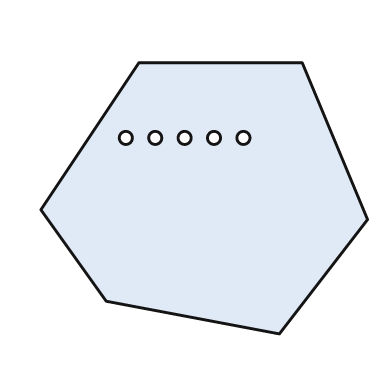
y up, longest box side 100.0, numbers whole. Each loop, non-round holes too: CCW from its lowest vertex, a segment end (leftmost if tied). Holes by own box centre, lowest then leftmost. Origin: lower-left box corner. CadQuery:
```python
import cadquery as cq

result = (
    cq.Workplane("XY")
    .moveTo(73.0, 0.0)
    .lineTo(100.0, 35.0)
    .lineTo(80.0, 83.0)
    .lineTo(30.0, 83.0)
    .lineTo(0.0, 38.0)
    .lineTo(20.0, 10.0)
    .close()
    .moveTo(26.0, 60.0)
    .circle(2.0)
    .moveTo(35.0, 60.0)
    .circle(2.0)
    .moveTo(44.0, 60.0)
    .circle(2.0)
    .moveTo(53.0, 60.0)
    .circle(2.0)
    .moveTo(62.0, 60.0)
    .circle(2.0)
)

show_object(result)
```